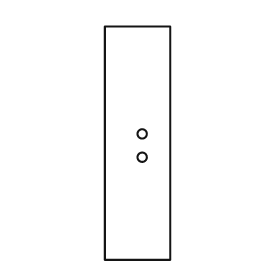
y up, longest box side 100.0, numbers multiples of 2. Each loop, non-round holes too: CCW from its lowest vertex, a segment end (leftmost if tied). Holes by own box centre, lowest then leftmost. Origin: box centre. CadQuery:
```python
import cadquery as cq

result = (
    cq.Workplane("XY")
    .moveTo(-14.0, -50.0)
    .lineTo(14.0, -50.0)
    .lineTo(14.0, 50.0)
    .lineTo(-14.0, 50.0)
    .close()
    .moveTo(2.0, -6.0)
    .circle(2.0)
    .moveTo(2.0, 4.0)
    .circle(2.0)
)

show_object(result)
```